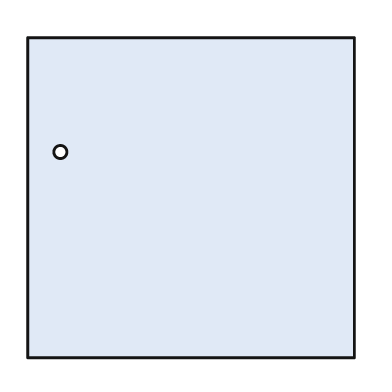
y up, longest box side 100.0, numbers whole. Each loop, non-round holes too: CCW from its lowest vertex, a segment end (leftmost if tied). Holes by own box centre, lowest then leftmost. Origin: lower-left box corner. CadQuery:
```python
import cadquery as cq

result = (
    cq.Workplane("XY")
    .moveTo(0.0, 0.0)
    .lineTo(100.0, 0.0)
    .lineTo(100.0, 98.0)
    .lineTo(0.0, 98.0)
    .close()
    .moveTo(10.0, 63.0)
    .circle(2.0)
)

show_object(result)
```